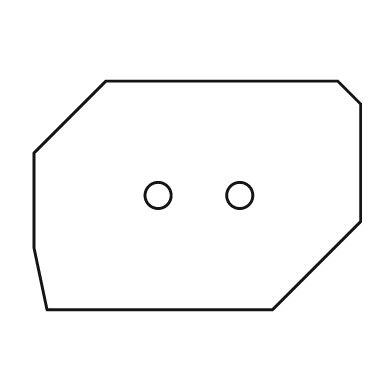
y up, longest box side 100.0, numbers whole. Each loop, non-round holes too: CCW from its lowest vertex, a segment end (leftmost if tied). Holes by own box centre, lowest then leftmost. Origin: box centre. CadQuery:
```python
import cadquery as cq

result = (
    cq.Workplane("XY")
    .moveTo(-46.0, -35.0)
    .lineTo(23.0, -35.0)
    .lineTo(50.0, -8.0)
    .lineTo(50.0, 28.0)
    .lineTo(43.0, 35.0)
    .lineTo(-28.0, 35.0)
    .lineTo(-50.0, 13.0)
    .lineTo(-50.0, -16.0)
    .close()
    .moveTo(-12.0, 0.0)
    .circle(4.0)
    .moveTo(13.0, 0.0)
    .circle(4.0)
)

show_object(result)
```